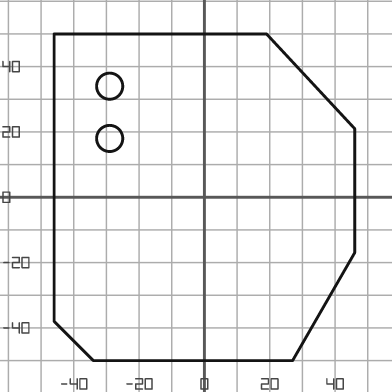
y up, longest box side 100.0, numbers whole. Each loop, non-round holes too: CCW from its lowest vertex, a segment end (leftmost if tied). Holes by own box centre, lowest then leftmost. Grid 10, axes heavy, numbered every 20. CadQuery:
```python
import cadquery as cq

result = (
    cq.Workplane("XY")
    .moveTo(-34.0, -50.0)
    .lineTo(27.0, -50.0)
    .lineTo(46.0, -17.0)
    .lineTo(46.0, 21.0)
    .lineTo(19.0, 50.0)
    .lineTo(-46.0, 50.0)
    .lineTo(-46.0, -38.0)
    .close()
    .moveTo(-29.0, 18.0)
    .circle(4.0)
    .moveTo(-29.0, 34.0)
    .circle(4.0)
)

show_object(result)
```